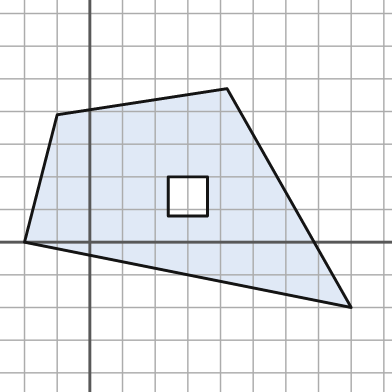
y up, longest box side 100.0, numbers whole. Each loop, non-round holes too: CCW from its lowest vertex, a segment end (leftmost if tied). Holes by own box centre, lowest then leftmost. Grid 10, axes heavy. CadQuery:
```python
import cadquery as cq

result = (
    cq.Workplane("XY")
    .moveTo(80.0, -20.0)
    .lineTo(42.0, 47.0)
    .lineTo(-10.0, 39.0)
    .lineTo(-20.0, 0.0)
    .close()
    .moveTo(24.0, 8.0)
    .lineTo(36.0, 8.0)
    .lineTo(36.0, 20.0)
    .lineTo(24.0, 20.0)
    .close()
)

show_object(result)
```